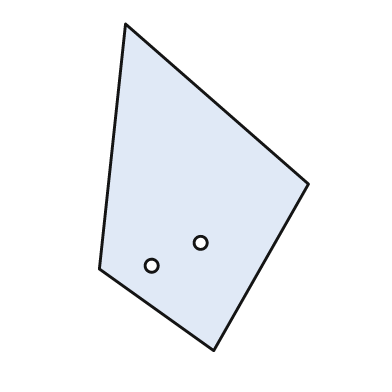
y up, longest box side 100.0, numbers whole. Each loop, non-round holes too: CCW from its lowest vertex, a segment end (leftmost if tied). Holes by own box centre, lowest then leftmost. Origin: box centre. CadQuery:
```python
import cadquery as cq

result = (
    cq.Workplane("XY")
    .moveTo(3.0, -50.0)
    .lineTo(32.0, 1.0)
    .lineTo(-24.0, 50.0)
    .lineTo(-32.0, -25.0)
    .close()
    .moveTo(-16.0, -24.0)
    .circle(2.0)
    .moveTo(-1.0, -17.0)
    .circle(2.0)
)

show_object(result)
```